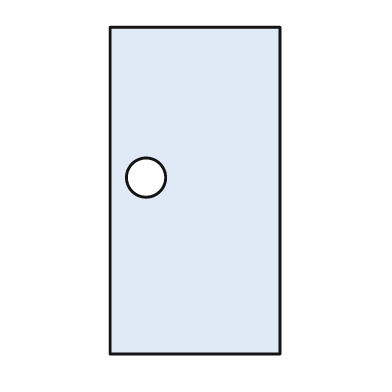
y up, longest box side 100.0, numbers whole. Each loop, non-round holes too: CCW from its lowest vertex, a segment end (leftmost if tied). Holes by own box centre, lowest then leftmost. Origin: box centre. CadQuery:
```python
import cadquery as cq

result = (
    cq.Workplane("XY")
    .moveTo(-26.0, -50.0)
    .lineTo(26.0, -50.0)
    .lineTo(26.0, 50.0)
    .lineTo(-26.0, 50.0)
    .close()
    .moveTo(-15.0, 4.0)
    .circle(6.0)
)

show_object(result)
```